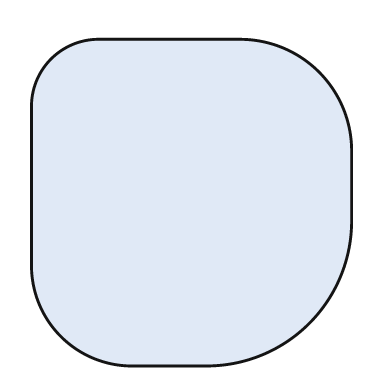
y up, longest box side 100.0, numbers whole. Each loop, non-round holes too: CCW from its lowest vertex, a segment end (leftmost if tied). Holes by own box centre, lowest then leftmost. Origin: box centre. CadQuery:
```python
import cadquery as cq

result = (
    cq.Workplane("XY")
    .moveTo(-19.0, -50.0)
    .lineTo(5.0, -50.0)
    .threePointArc((36.0, -37.0), (49.0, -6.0))
    .lineTo(49.0, 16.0)
    .threePointArc((39.0, 40.0), (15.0, 50.0))
    .lineTo(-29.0, 50.0)
    .threePointArc((-43.0, 44.0), (-49.0, 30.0))
    .lineTo(-49.0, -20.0)
    .threePointArc((-40.0, -41.0), (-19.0, -50.0))
    .close()
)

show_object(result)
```